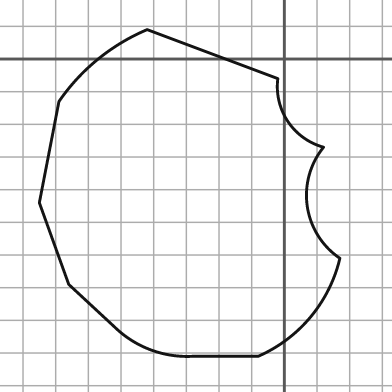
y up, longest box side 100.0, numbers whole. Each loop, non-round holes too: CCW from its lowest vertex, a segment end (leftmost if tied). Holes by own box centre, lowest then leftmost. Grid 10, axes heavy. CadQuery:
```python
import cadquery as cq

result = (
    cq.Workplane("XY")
    .moveTo(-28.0, -91.0)
    .lineTo(-8.0, -91.0)
    .threePointArc((8.0, -79.0), (17.0, -61.0))
    .threePointArc((7.0, -45.0), (12.0, -27.0))
    .threePointArc((1.0, -19.0), (-2.0, -6.0))
    .lineTo(-42.0, 9.0)
    .threePointArc((-57.0, 0.0), (-69.0, -13.0))
    .lineTo(-75.0, -44.0)
    .lineTo(-66.0, -69.0)
    .lineTo(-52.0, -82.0)
    .threePointArc((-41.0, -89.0), (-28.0, -91.0))
    .close()
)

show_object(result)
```